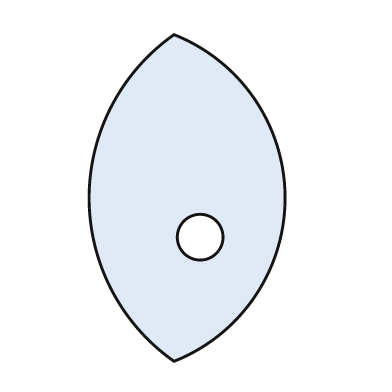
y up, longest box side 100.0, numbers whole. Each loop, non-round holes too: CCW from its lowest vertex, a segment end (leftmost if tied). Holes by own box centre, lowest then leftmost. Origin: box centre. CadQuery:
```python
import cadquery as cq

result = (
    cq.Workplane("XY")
    .moveTo(-4.0, -50.0)
    .threePointArc((30.0, 0.0), (-4.0, 50.0))
    .threePointArc((-30.0, 0.0), (-4.0, -50.0))
    .close()
    .moveTo(4.0, -12.0)
    .circle(7.0)
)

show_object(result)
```